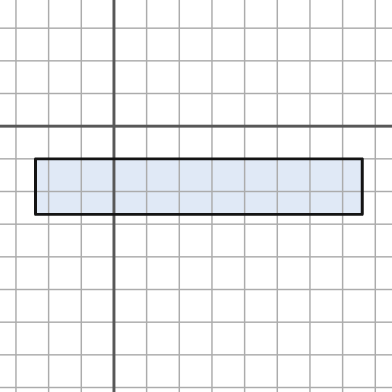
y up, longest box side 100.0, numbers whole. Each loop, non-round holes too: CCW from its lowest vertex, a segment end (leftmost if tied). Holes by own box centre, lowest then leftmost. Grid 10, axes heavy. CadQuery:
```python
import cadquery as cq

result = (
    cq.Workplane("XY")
    .moveTo(-24.0, -27.0)
    .lineTo(76.0, -27.0)
    .lineTo(76.0, -10.0)
    .lineTo(-24.0, -10.0)
    .close()
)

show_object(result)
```